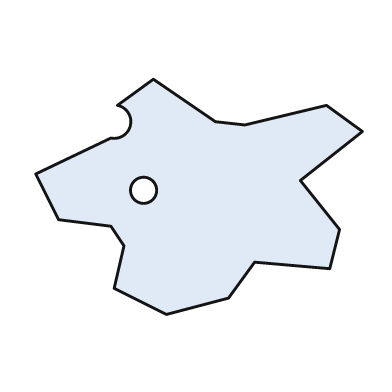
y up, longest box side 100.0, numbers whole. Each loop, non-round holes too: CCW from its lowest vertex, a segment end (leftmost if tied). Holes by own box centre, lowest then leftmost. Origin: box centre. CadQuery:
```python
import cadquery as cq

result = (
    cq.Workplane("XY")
    .moveTo(-10.0, -36.0)
    .lineTo(9.0, -31.0)
    .lineTo(17.0, -20.0)
    .lineTo(40.0, -22.0)
    .lineTo(43.0, -10.0)
    .lineTo(31.0, 5.0)
    .lineTo(50.0, 20.0)
    .lineTo(39.0, 28.0)
    .lineTo(14.0, 22.0)
    .lineTo(5.0, 23.0)
    .lineTo(-14.0, 36.0)
    .lineTo(-25.0, 28.0)
    .threePointArc((-21.0, 22.0), (-27.0, 18.0))
    .lineTo(-50.0, 7.0)
    .lineTo(-43.0, -7.0)
    .lineTo(-27.0, -9.0)
    .lineTo(-23.0, -15.0)
    .lineTo(-26.0, -28.0)
    .close()
    .moveTo(-17.0, 2.0)
    .circle(4.0)
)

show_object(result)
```